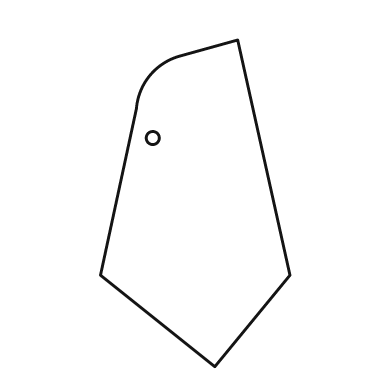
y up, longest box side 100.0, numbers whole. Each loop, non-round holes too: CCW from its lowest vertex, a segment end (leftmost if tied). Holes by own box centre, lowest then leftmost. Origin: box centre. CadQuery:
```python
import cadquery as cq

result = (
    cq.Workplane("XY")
    .moveTo(6.0, -50.0)
    .lineTo(29.0, -22.0)
    .lineTo(13.0, 50.0)
    .lineTo(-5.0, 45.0)
    .threePointArc((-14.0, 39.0), (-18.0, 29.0))
    .lineTo(-29.0, -22.0)
    .close()
    .moveTo(-13.0, 20.0)
    .circle(2.0)
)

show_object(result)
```